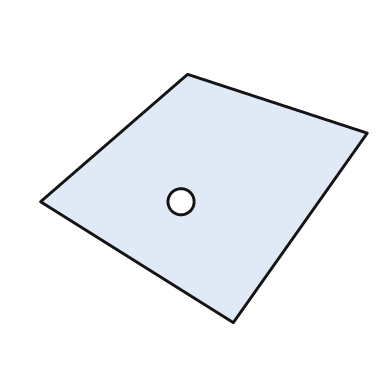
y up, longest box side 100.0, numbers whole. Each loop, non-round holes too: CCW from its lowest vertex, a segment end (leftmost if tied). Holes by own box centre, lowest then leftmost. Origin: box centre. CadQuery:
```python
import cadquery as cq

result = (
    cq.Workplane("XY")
    .moveTo(9.0, -38.0)
    .lineTo(50.0, 20.0)
    .lineTo(-5.0, 38.0)
    .lineTo(-50.0, -1.0)
    .close()
    .moveTo(-7.0, -1.0)
    .circle(4.0)
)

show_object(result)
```